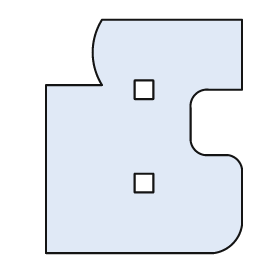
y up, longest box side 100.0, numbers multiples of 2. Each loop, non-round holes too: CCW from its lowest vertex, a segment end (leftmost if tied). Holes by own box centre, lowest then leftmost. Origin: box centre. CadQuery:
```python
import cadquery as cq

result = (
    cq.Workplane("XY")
    .moveTo(-42.0, -50.0)
    .lineTo(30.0, -50.0)
    .threePointArc((38.0, -46.0), (42.0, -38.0))
    .lineTo(42.0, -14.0)
    .threePointArc((40.0, -10.0), (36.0, -8.0))
    .lineTo(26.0, -8.0)
    .threePointArc((22.0, -6.0), (20.0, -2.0))
    .lineTo(20.0, 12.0)
    .threePointArc((22.0, 18.0), (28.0, 20.0))
    .lineTo(42.0, 20.0)
    .lineTo(42.0, 50.0)
    .lineTo(-18.0, 50.0)
    .threePointArc((-22.0, 36.0), (-18.0, 22.0))
    .lineTo(-42.0, 22.0)
    .close()
    .moveTo(-4.0, -24.0)
    .lineTo(4.0, -24.0)
    .lineTo(4.0, -16.0)
    .lineTo(-4.0, -16.0)
    .close()
    .moveTo(-4.0, 16.0)
    .lineTo(4.0, 16.0)
    .lineTo(4.0, 24.0)
    .lineTo(-4.0, 24.0)
    .close()
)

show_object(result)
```